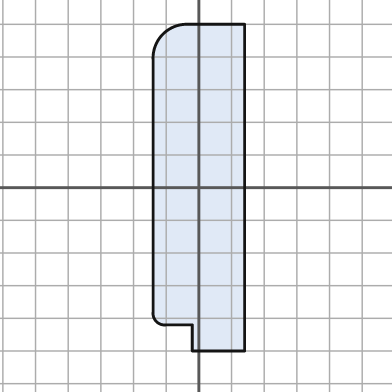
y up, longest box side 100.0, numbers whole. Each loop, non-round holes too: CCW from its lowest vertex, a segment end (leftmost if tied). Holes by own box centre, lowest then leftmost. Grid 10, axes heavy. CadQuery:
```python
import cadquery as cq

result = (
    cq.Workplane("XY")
    .moveTo(-2.0, -50.0)
    .lineTo(14.0, -50.0)
    .lineTo(14.0, 50.0)
    .lineTo(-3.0, 50.0)
    .threePointArc((-11.0, 47.0), (-14.0, 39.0))
    .lineTo(-14.0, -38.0)
    .threePointArc((-13.0, -41.0), (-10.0, -42.0))
    .lineTo(-2.0, -42.0)
    .close()
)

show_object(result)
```